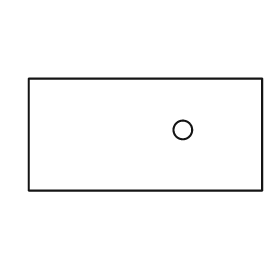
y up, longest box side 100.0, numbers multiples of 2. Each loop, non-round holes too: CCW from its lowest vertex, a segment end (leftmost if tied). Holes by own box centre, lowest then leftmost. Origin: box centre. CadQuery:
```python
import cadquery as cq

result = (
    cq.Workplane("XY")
    .moveTo(-50.0, -24.0)
    .lineTo(50.0, -24.0)
    .lineTo(50.0, 24.0)
    .lineTo(-50.0, 24.0)
    .close()
    .moveTo(16.0, 2.0)
    .circle(4.0)
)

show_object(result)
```